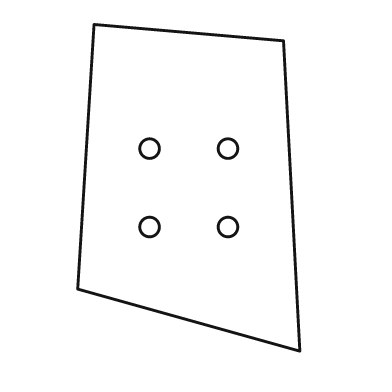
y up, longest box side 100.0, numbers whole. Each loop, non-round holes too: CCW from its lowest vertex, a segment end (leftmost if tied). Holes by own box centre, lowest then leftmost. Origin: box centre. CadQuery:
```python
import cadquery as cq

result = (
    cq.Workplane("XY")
    .moveTo(34.0, -50.0)
    .lineTo(29.0, 45.0)
    .lineTo(-29.0, 50.0)
    .lineTo(-34.0, -31.0)
    .close()
    .moveTo(-12.0, -12.0)
    .circle(3.0)
    .moveTo(12.0, -12.0)
    .circle(3.0)
    .moveTo(-12.0, 12.0)
    .circle(3.0)
    .moveTo(12.0, 12.0)
    .circle(3.0)
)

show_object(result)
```